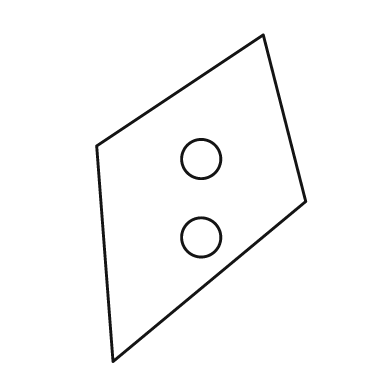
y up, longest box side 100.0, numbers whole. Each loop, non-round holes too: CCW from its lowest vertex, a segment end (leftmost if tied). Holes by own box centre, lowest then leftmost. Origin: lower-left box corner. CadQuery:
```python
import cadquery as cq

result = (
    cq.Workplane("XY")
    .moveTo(5.0, 0.0)
    .lineTo(64.0, 49.0)
    .lineTo(51.0, 100.0)
    .lineTo(0.0, 66.0)
    .close()
    .moveTo(32.0, 38.0)
    .circle(6.0)
    .moveTo(32.0, 62.0)
    .circle(6.0)
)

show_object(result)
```